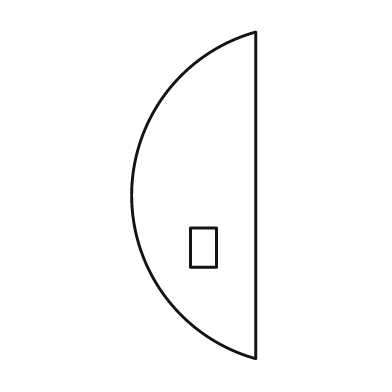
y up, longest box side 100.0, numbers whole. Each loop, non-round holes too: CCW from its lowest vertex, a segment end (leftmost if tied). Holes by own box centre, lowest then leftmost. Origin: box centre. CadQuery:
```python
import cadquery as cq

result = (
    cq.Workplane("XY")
    .moveTo(19.0, -50.0)
    .lineTo(19.0, 50.0)
    .threePointArc((-19.0, 0.0), (19.0, -50.0))
    .close()
    .moveTo(-1.0, -22.0)
    .lineTo(7.0, -22.0)
    .lineTo(7.0, -10.0)
    .lineTo(-1.0, -10.0)
    .close()
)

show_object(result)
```